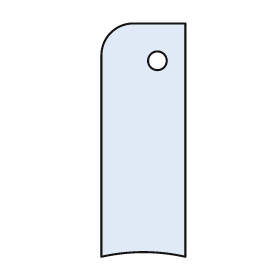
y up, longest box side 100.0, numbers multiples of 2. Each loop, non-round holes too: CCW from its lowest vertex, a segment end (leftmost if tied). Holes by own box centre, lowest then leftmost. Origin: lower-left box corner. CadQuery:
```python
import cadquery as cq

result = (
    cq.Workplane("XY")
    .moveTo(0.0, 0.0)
    .threePointArc((18.0, 2.0), (36.0, 0.0))
    .lineTo(36.0, 100.0)
    .lineTo(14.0, 100.0)
    .threePointArc((4.0, 96.0), (0.0, 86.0))
    .close()
    .moveTo(24.0, 84.0)
    .circle(4.0)
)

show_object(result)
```